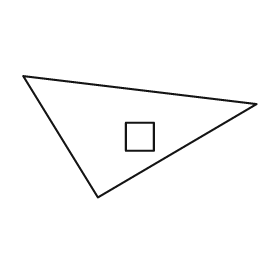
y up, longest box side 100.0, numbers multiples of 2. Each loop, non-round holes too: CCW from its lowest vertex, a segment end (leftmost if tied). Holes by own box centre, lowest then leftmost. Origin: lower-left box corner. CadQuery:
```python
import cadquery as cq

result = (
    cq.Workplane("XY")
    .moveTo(32.0, 0.0)
    .lineTo(100.0, 40.0)
    .lineTo(0.0, 52.0)
    .close()
    .moveTo(44.0, 20.0)
    .lineTo(56.0, 20.0)
    .lineTo(56.0, 32.0)
    .lineTo(44.0, 32.0)
    .close()
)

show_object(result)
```